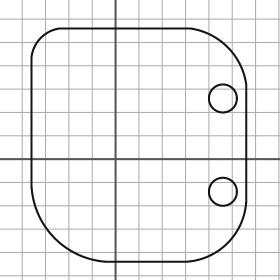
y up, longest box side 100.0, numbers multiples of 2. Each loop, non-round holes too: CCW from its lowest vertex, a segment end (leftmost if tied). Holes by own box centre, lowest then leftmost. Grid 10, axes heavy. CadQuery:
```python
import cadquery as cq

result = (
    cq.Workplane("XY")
    .moveTo(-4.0, -44.0)
    .lineTo(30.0, -44.0)
    .threePointArc((48.0, -36.0), (56.0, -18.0))
    .lineTo(56.0, 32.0)
    .threePointArc((48.0, 48.0), (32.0, 56.0))
    .lineTo(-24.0, 56.0)
    .threePointArc((-32.0, 52.0), (-36.0, 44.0))
    .lineTo(-36.0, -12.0)
    .threePointArc((-26.0, -34.0), (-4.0, -44.0))
    .close()
    .moveTo(46.0, -14.0)
    .circle(6.0)
    .moveTo(46.0, 26.0)
    .circle(6.0)
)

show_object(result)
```